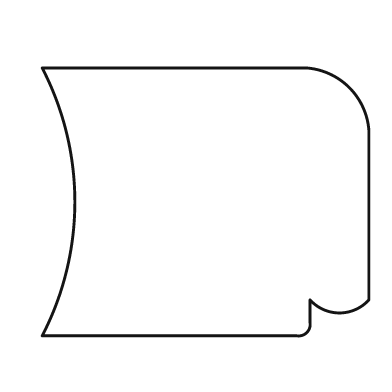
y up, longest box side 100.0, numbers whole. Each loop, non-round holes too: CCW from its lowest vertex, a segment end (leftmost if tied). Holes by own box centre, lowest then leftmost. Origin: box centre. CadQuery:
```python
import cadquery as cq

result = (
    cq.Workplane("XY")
    .moveTo(-50.0, -41.0)
    .lineTo(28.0, -41.0)
    .threePointArc((31.0, -40.0), (32.0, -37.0))
    .lineTo(32.0, -30.0)
    .threePointArc((41.0, -34.0), (50.0, -30.0))
    .lineTo(50.0, 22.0)
    .threePointArc((44.0, 35.0), (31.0, 41.0))
    .lineTo(-50.0, 41.0)
    .threePointArc((-40.0, 0.0), (-50.0, -41.0))
    .close()
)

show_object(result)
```